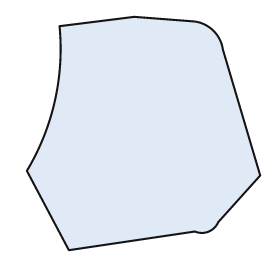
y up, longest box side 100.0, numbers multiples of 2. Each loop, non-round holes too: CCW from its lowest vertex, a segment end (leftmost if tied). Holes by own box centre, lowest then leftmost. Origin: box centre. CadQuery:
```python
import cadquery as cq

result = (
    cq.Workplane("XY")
    .moveTo(-32.0, -50.0)
    .lineTo(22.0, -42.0)
    .threePointArc((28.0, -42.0), (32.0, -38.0))
    .lineTo(50.0, -18.0)
    .lineTo(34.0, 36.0)
    .threePointArc((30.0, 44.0), (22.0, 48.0))
    .lineTo(-4.0, 50.0)
    .lineTo(-36.0, 46.0)
    .threePointArc((-38.0, 14.0), (-50.0, -16.0))
    .close()
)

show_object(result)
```